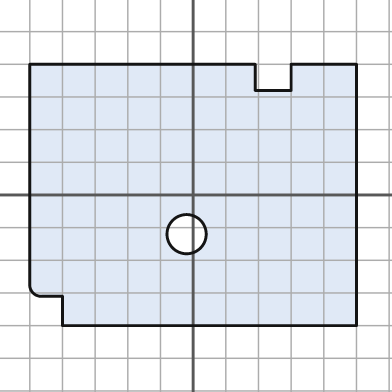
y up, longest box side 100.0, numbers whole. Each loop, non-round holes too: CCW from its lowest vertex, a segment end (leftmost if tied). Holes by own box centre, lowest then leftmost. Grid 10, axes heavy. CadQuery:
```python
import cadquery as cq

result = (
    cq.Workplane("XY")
    .moveTo(-40.0, -40.0)
    .lineTo(50.0, -40.0)
    .lineTo(50.0, 40.0)
    .lineTo(30.0, 40.0)
    .lineTo(30.0, 32.0)
    .lineTo(19.0, 32.0)
    .lineTo(19.0, 40.0)
    .lineTo(-50.0, 40.0)
    .lineTo(-50.0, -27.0)
    .threePointArc((-49.0, -30.0), (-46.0, -31.0))
    .lineTo(-40.0, -31.0)
    .close()
    .moveTo(-2.0, -12.0)
    .circle(6.0)
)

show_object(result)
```